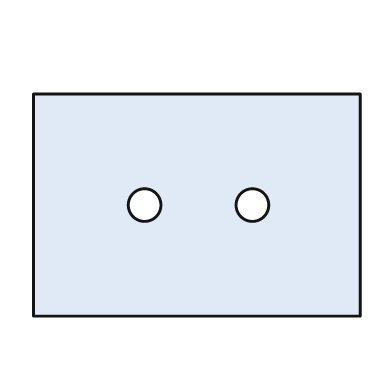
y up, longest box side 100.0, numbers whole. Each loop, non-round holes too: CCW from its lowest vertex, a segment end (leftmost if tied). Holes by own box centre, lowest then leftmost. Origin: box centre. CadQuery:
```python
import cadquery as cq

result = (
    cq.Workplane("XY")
    .moveTo(-50.0, -34.0)
    .lineTo(50.0, -34.0)
    .lineTo(50.0, 34.0)
    .lineTo(-50.0, 34.0)
    .close()
    .moveTo(-16.0, 0.0)
    .circle(5.0)
    .moveTo(17.0, 0.0)
    .circle(5.0)
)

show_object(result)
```